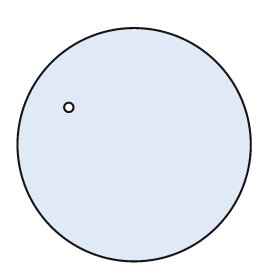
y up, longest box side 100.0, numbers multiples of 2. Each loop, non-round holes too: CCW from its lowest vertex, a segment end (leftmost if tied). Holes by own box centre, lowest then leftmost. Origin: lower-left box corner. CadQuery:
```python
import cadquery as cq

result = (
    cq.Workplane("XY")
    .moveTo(50.0, 50.0)
    .circle(50.0)
    .moveTo(22.0, 66.0)
    .circle(2.0)
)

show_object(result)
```